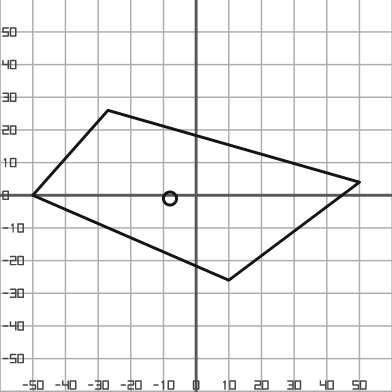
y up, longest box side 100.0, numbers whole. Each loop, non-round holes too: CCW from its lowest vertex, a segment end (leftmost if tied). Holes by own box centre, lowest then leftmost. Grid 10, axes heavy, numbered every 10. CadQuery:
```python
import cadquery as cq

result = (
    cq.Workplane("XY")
    .moveTo(10.0, -26.0)
    .lineTo(50.0, 4.0)
    .lineTo(-27.0, 26.0)
    .lineTo(-50.0, 0.0)
    .close()
    .moveTo(-8.0, -1.0)
    .circle(2.0)
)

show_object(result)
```